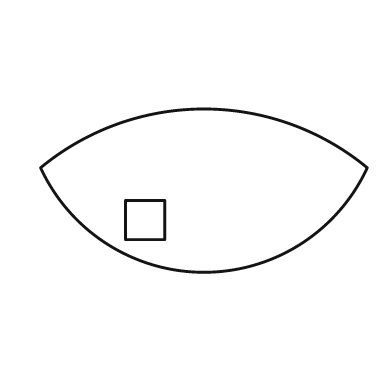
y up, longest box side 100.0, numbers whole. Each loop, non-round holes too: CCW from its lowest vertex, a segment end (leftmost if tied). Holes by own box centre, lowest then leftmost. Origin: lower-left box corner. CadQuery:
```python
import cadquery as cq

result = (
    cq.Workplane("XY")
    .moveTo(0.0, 32.0)
    .threePointArc((50.0, 0.0), (100.0, 32.0))
    .threePointArc((50.0, 50.0), (0.0, 32.0))
    .close()
    .moveTo(26.0, 10.0)
    .lineTo(38.0, 10.0)
    .lineTo(38.0, 22.0)
    .lineTo(26.0, 22.0)
    .close()
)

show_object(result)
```